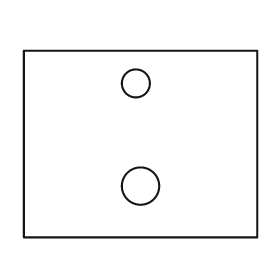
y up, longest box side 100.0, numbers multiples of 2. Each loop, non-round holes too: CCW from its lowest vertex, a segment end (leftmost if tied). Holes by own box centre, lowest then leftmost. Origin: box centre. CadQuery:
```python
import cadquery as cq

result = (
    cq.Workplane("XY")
    .moveTo(-50.0, -40.0)
    .lineTo(50.0, -40.0)
    .lineTo(50.0, 40.0)
    .lineTo(-50.0, 40.0)
    .close()
    .moveTo(0.0, -18.0)
    .circle(8.0)
    .moveTo(-2.0, 26.0)
    .circle(6.0)
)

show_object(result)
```